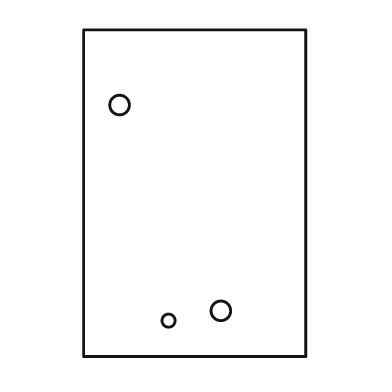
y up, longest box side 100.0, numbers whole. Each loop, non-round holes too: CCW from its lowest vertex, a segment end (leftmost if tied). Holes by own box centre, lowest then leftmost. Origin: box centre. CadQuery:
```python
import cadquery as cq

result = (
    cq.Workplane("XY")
    .moveTo(-34.0, -50.0)
    .lineTo(34.0, -50.0)
    .lineTo(34.0, 50.0)
    .lineTo(-34.0, 50.0)
    .close()
    .moveTo(-8.0, -39.0)
    .circle(2.0)
    .moveTo(8.0, -36.0)
    .circle(3.0)
    .moveTo(-23.0, 27.0)
    .circle(3.0)
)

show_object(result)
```